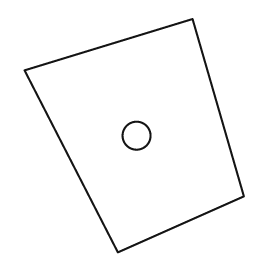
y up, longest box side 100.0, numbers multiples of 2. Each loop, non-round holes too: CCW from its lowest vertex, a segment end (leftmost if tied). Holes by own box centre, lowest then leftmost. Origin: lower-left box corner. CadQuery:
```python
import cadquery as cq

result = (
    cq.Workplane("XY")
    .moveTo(40.0, 0.0)
    .lineTo(94.0, 24.0)
    .lineTo(72.0, 100.0)
    .lineTo(0.0, 78.0)
    .close()
    .moveTo(48.0, 50.0)
    .circle(6.0)
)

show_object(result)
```